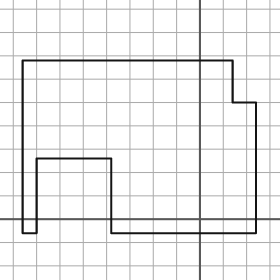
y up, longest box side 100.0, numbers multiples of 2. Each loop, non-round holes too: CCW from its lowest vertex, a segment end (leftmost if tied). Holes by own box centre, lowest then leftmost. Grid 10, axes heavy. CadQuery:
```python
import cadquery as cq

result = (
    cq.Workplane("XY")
    .moveTo(-76.0, -6.0)
    .lineTo(-70.0, -6.0)
    .lineTo(-70.0, 26.0)
    .lineTo(-38.0, 26.0)
    .lineTo(-38.0, -6.0)
    .lineTo(24.0, -6.0)
    .lineTo(24.0, 50.0)
    .lineTo(14.0, 50.0)
    .lineTo(14.0, 68.0)
    .lineTo(-76.0, 68.0)
    .close()
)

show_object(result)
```